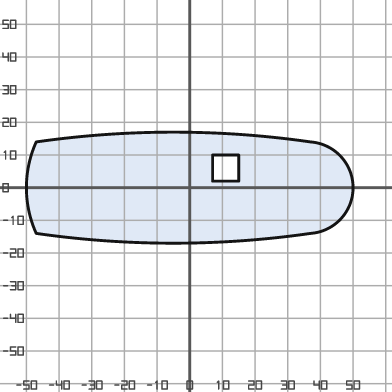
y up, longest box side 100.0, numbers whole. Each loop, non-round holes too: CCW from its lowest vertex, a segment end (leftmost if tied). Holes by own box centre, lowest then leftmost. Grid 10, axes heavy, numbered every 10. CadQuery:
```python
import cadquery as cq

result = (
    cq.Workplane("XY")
    .moveTo(-47.0, -14.0)
    .threePointArc((-5.0, -17.0), (37.0, -14.0))
    .threePointArc((50.0, 0.0), (37.0, 14.0))
    .threePointArc((-5.0, 17.0), (-47.0, 14.0))
    .threePointArc((-50.0, 0.0), (-47.0, -14.0))
    .close()
    .moveTo(7.0, 2.0)
    .lineTo(15.0, 2.0)
    .lineTo(15.0, 10.0)
    .lineTo(7.0, 10.0)
    .close()
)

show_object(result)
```